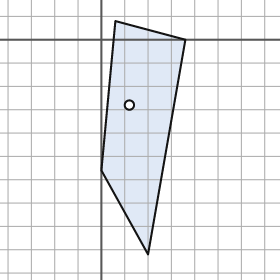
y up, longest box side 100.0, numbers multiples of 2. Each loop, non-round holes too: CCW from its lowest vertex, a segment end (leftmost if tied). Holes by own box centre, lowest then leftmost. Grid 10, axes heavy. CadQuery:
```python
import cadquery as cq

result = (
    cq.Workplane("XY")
    .moveTo(20.0, -92.0)
    .lineTo(36.0, 0.0)
    .lineTo(6.0, 8.0)
    .lineTo(0.0, -56.0)
    .close()
    .moveTo(12.0, -28.0)
    .circle(2.0)
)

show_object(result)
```